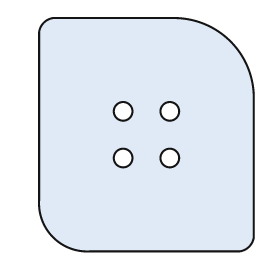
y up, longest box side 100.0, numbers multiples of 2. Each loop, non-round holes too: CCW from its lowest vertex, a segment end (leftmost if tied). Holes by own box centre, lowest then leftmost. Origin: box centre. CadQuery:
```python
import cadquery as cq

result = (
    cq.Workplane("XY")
    .moveTo(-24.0, -50.0)
    .lineTo(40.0, -50.0)
    .threePointArc((44.0, -48.0), (46.0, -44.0))
    .lineTo(46.0, 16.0)
    .threePointArc((36.0, 40.0), (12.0, 50.0))
    .lineTo(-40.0, 50.0)
    .threePointArc((-44.0, 48.0), (-46.0, 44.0))
    .lineTo(-46.0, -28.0)
    .threePointArc((-40.0, -44.0), (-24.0, -50.0))
    .close()
    .moveTo(-10.0, -10.0)
    .circle(4.0)
    .moveTo(10.0, -10.0)
    .circle(4.0)
    .moveTo(-10.0, 10.0)
    .circle(4.0)
    .moveTo(10.0, 10.0)
    .circle(4.0)
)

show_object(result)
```